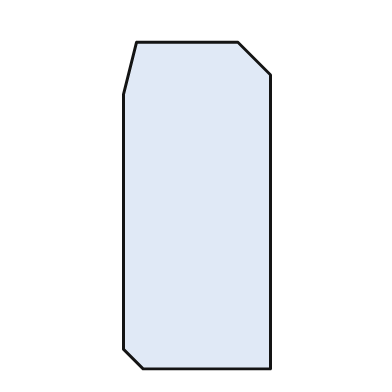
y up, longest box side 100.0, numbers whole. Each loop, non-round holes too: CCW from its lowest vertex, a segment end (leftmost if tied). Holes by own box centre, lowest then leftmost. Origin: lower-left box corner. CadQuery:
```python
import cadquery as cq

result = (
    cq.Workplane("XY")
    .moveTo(6.0, 0.0)
    .lineTo(45.0, 0.0)
    .lineTo(45.0, 90.0)
    .lineTo(35.0, 100.0)
    .lineTo(4.0, 100.0)
    .lineTo(0.0, 84.0)
    .lineTo(0.0, 6.0)
    .close()
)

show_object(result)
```